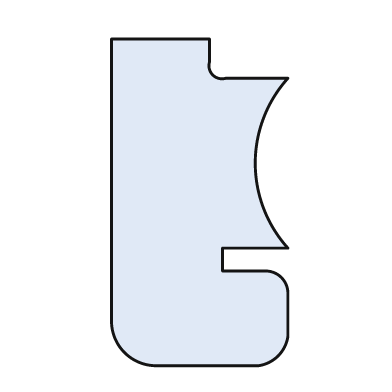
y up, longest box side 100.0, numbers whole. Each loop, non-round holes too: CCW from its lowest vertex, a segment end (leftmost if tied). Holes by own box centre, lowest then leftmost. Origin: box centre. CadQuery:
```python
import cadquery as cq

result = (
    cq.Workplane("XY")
    .moveTo(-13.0, -50.0)
    .lineTo(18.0, -50.0)
    .threePointArc((24.0, -47.0), (27.0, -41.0))
    .lineTo(27.0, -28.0)
    .threePointArc((25.0, -23.0), (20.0, -21.0))
    .lineTo(7.0, -21.0)
    .lineTo(7.0, -14.0)
    .lineTo(27.0, -14.0)
    .threePointArc((17.0, 12.0), (27.0, 38.0))
    .lineTo(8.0, 38.0)
    .threePointArc((4.0, 39.0), (3.0, 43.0))
    .lineTo(3.0, 50.0)
    .lineTo(-27.0, 50.0)
    .lineTo(-27.0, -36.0)
    .threePointArc((-23.0, -46.0), (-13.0, -50.0))
    .close()
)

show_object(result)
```